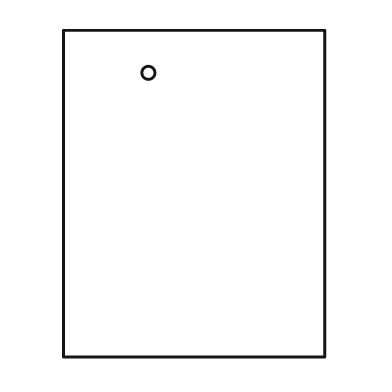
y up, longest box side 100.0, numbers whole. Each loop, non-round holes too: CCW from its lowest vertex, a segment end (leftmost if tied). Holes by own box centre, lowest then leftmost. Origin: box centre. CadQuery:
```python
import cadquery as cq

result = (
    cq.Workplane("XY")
    .moveTo(-40.0, -50.0)
    .lineTo(40.0, -50.0)
    .lineTo(40.0, 50.0)
    .lineTo(-40.0, 50.0)
    .close()
    .moveTo(-14.0, 37.0)
    .circle(2.0)
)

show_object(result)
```